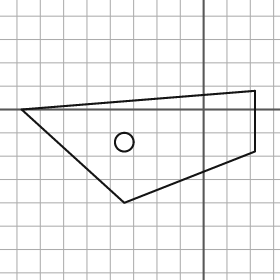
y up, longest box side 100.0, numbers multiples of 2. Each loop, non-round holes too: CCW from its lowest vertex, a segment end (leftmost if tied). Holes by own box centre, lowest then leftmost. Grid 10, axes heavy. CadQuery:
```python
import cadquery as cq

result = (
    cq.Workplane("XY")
    .moveTo(-34.0, -40.0)
    .lineTo(22.0, -18.0)
    .lineTo(22.0, 8.0)
    .lineTo(-78.0, 0.0)
    .close()
    .moveTo(-34.0, -14.0)
    .circle(4.0)
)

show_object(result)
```